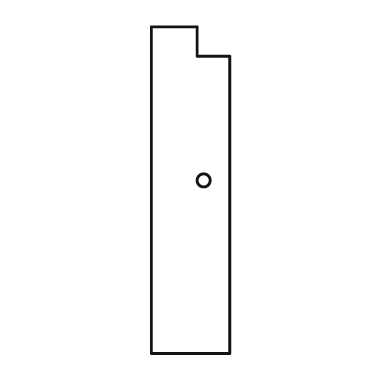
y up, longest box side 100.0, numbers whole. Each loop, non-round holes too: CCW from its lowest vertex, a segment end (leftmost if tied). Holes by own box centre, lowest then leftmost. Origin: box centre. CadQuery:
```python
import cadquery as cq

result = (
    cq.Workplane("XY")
    .moveTo(-12.0, -50.0)
    .lineTo(12.0, -50.0)
    .lineTo(12.0, 41.0)
    .lineTo(2.0, 41.0)
    .lineTo(2.0, 50.0)
    .lineTo(-12.0, 50.0)
    .close()
    .moveTo(4.0, 3.0)
    .circle(2.0)
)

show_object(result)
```